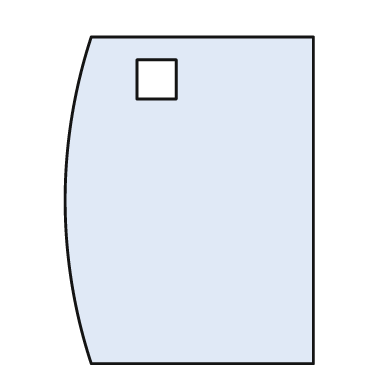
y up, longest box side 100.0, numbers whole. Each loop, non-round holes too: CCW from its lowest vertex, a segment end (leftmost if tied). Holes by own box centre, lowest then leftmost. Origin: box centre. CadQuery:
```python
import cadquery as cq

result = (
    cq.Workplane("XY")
    .moveTo(-30.0, -50.0)
    .lineTo(38.0, -50.0)
    .lineTo(38.0, 50.0)
    .lineTo(-30.0, 50.0)
    .threePointArc((-38.0, 0.0), (-30.0, -50.0))
    .close()
    .moveTo(-16.0, 31.0)
    .lineTo(-4.0, 31.0)
    .lineTo(-4.0, 43.0)
    .lineTo(-16.0, 43.0)
    .close()
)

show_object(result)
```